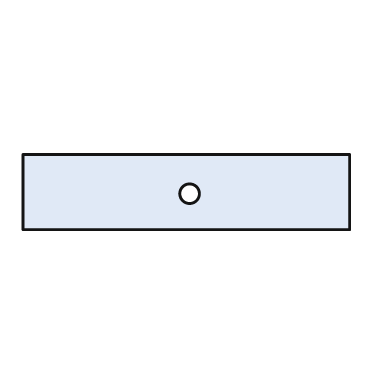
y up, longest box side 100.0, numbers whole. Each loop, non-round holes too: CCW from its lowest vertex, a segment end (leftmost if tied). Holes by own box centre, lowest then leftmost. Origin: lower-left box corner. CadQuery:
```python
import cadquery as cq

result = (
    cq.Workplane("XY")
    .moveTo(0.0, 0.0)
    .lineTo(100.0, 0.0)
    .lineTo(100.0, 23.0)
    .lineTo(0.0, 23.0)
    .close()
    .moveTo(51.0, 11.0)
    .circle(3.0)
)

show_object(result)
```